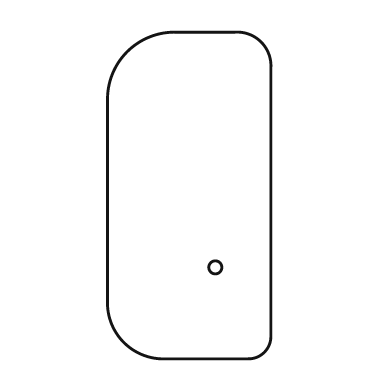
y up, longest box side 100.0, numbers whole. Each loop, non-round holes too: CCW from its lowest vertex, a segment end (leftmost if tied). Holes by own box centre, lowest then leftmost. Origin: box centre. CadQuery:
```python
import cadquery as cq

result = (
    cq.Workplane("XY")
    .moveTo(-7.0, -50.0)
    .lineTo(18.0, -50.0)
    .threePointArc((23.0, -48.0), (25.0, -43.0))
    .lineTo(25.0, 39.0)
    .threePointArc((22.0, 47.0), (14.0, 50.0))
    .lineTo(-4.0, 50.0)
    .threePointArc((-19.0, 44.0), (-25.0, 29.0))
    .lineTo(-25.0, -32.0)
    .threePointArc((-20.0, -45.0), (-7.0, -50.0))
    .close()
    .moveTo(8.0, -22.0)
    .circle(2.0)
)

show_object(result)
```